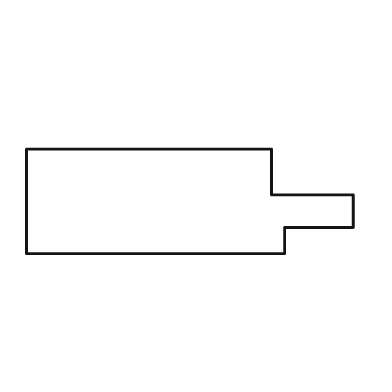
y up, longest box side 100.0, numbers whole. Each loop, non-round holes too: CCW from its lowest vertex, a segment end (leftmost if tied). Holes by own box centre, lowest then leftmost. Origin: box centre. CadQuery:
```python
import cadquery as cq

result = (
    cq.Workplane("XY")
    .moveTo(-50.0, -16.0)
    .lineTo(29.0, -16.0)
    .lineTo(29.0, -8.0)
    .lineTo(50.0, -8.0)
    .lineTo(50.0, 2.0)
    .lineTo(25.0, 2.0)
    .lineTo(25.0, 16.0)
    .lineTo(-50.0, 16.0)
    .close()
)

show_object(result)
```